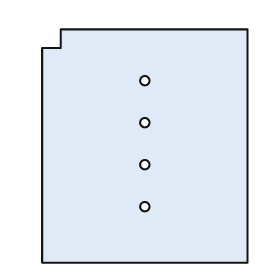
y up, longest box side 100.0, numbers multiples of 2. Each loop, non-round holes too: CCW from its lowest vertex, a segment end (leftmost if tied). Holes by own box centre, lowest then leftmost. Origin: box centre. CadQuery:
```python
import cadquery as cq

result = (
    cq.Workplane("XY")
    .moveTo(-44.0, -50.0)
    .lineTo(44.0, -50.0)
    .lineTo(44.0, 50.0)
    .lineTo(-36.0, 50.0)
    .lineTo(-36.0, 42.0)
    .lineTo(-44.0, 42.0)
    .close()
    .moveTo(0.0, -26.0)
    .circle(2.0)
    .moveTo(0.0, -8.0)
    .circle(2.0)
    .moveTo(0.0, 10.0)
    .circle(2.0)
    .moveTo(0.0, 28.0)
    .circle(2.0)
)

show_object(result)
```